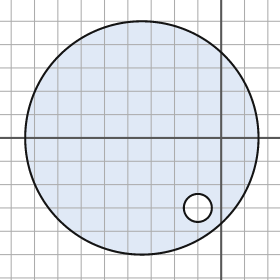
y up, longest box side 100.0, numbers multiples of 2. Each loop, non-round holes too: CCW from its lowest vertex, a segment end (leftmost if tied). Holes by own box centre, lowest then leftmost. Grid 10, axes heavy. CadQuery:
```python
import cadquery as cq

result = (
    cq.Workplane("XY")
    .moveTo(-34.0, 0.0)
    .circle(50.0)
    .moveTo(-10.0, -30.0)
    .circle(6.0)
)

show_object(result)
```